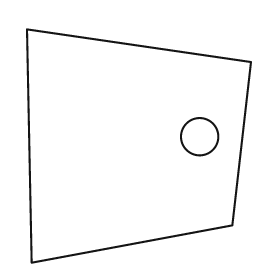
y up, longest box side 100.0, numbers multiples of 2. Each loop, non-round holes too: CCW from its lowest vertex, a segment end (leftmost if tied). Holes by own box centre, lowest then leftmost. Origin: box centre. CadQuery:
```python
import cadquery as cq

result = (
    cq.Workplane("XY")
    .moveTo(-46.0, -50.0)
    .lineTo(40.0, -34.0)
    .lineTo(48.0, 36.0)
    .lineTo(-48.0, 50.0)
    .close()
    .moveTo(26.0, 4.0)
    .circle(8.0)
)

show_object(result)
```